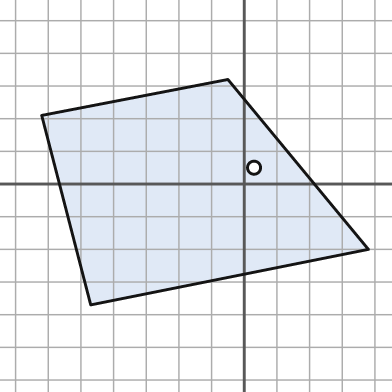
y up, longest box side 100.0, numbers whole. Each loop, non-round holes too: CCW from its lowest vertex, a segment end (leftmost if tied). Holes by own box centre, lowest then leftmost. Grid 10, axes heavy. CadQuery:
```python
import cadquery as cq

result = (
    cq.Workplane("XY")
    .moveTo(-47.0, -37.0)
    .lineTo(38.0, -20.0)
    .lineTo(-5.0, 32.0)
    .lineTo(-62.0, 21.0)
    .close()
    .moveTo(3.0, 5.0)
    .circle(2.0)
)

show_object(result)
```